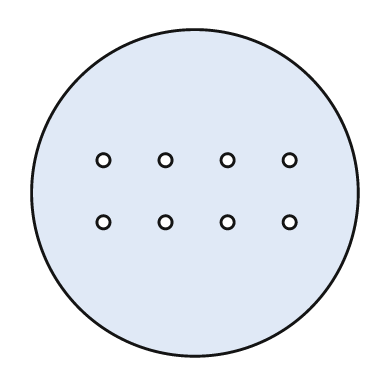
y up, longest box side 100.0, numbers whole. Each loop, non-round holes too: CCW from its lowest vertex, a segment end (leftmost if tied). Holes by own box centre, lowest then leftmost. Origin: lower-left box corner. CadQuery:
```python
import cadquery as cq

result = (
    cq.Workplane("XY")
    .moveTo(50.0, 50.0)
    .circle(50.0)
    .moveTo(22.0, 41.0)
    .circle(2.0)
    .moveTo(41.0, 41.0)
    .circle(2.0)
    .moveTo(60.0, 41.0)
    .circle(2.0)
    .moveTo(79.0, 41.0)
    .circle(2.0)
    .moveTo(22.0, 60.0)
    .circle(2.0)
    .moveTo(41.0, 60.0)
    .circle(2.0)
    .moveTo(60.0, 60.0)
    .circle(2.0)
    .moveTo(79.0, 60.0)
    .circle(2.0)
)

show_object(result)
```